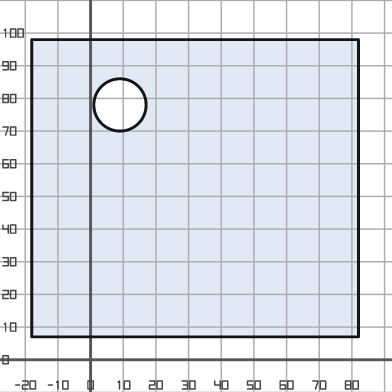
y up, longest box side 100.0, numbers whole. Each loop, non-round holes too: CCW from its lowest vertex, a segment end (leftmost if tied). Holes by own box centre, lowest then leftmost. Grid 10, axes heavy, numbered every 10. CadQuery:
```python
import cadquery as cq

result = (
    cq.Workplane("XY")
    .moveTo(-18.0, 7.0)
    .lineTo(82.0, 7.0)
    .lineTo(82.0, 98.0)
    .lineTo(-18.0, 98.0)
    .close()
    .moveTo(9.0, 78.0)
    .circle(8.0)
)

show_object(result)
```